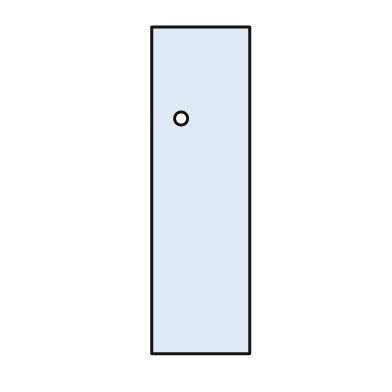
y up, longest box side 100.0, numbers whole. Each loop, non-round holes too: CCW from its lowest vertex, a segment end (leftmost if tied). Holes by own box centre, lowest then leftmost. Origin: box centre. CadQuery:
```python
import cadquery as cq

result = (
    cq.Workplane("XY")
    .moveTo(-15.0, -50.0)
    .lineTo(15.0, -50.0)
    .lineTo(15.0, 50.0)
    .lineTo(-15.0, 50.0)
    .close()
    .moveTo(-6.0, 22.0)
    .circle(2.0)
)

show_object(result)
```